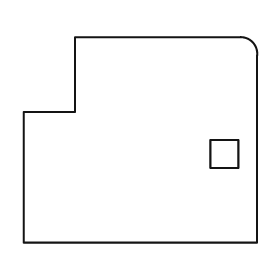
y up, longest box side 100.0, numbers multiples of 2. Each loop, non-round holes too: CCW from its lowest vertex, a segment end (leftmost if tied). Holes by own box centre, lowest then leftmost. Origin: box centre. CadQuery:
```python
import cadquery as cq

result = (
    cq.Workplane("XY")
    .moveTo(-50.0, -44.0)
    .lineTo(50.0, -44.0)
    .lineTo(50.0, 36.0)
    .threePointArc((48.0, 42.0), (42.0, 44.0))
    .lineTo(-28.0, 44.0)
    .lineTo(-28.0, 12.0)
    .lineTo(-50.0, 12.0)
    .close()
    .moveTo(30.0, -12.0)
    .lineTo(42.0, -12.0)
    .lineTo(42.0, 0.0)
    .lineTo(30.0, 0.0)
    .close()
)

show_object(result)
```